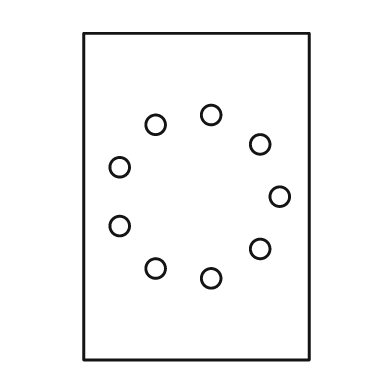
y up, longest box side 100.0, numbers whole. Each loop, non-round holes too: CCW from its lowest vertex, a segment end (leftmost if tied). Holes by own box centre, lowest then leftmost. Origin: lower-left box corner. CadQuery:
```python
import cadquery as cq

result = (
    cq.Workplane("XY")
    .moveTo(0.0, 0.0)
    .lineTo(69.0, 0.0)
    .lineTo(69.0, 100.0)
    .lineTo(0.0, 100.0)
    .close()
    .moveTo(39.0, 25.0)
    .circle(3.0)
    .moveTo(22.0, 28.0)
    .circle(3.0)
    .moveTo(54.0, 34.0)
    .circle(3.0)
    .moveTo(11.0, 41.0)
    .circle(3.0)
    .moveTo(60.0, 50.0)
    .circle(3.0)
    .moveTo(11.0, 59.0)
    .circle(3.0)
    .moveTo(54.0, 66.0)
    .circle(3.0)
    .moveTo(22.0, 72.0)
    .circle(3.0)
    .moveTo(39.0, 75.0)
    .circle(3.0)
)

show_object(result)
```